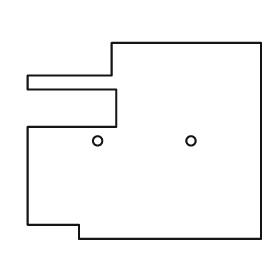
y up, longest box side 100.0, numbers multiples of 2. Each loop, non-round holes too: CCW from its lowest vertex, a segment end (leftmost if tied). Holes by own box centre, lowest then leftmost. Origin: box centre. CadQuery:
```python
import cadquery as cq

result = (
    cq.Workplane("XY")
    .moveTo(-28.0, -42.0)
    .lineTo(50.0, -42.0)
    .lineTo(50.0, 42.0)
    .lineTo(-14.0, 42.0)
    .lineTo(-14.0, 28.0)
    .lineTo(-50.0, 28.0)
    .lineTo(-50.0, 22.0)
    .lineTo(-12.0, 22.0)
    .lineTo(-12.0, 6.0)
    .lineTo(-50.0, 6.0)
    .lineTo(-50.0, -36.0)
    .lineTo(-28.0, -36.0)
    .close()
    .moveTo(-20.0, 0.0)
    .circle(2.0)
    .moveTo(20.0, 0.0)
    .circle(2.0)
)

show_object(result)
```